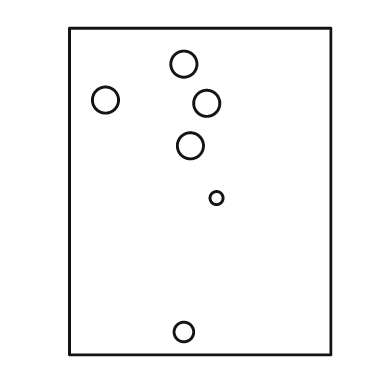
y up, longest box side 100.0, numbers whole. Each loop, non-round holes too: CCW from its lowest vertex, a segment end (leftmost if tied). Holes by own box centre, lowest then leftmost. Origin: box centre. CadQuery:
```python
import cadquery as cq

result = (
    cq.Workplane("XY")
    .moveTo(-40.0, -50.0)
    .lineTo(40.0, -50.0)
    .lineTo(40.0, 50.0)
    .lineTo(-40.0, 50.0)
    .close()
    .moveTo(-5.0, -43.0)
    .circle(3.0)
    .moveTo(5.0, -2.0)
    .circle(2.0)
    .moveTo(-3.0, 14.0)
    .circle(4.0)
    .moveTo(2.0, 27.0)
    .circle(4.0)
    .moveTo(-29.0, 28.0)
    .circle(4.0)
    .moveTo(-5.0, 39.0)
    .circle(4.0)
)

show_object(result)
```